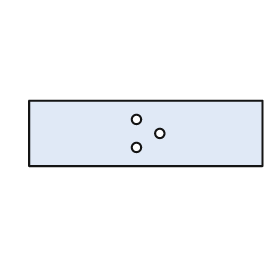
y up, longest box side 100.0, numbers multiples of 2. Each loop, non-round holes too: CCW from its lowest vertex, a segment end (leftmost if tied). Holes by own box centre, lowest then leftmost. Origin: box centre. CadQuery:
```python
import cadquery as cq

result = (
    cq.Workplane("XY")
    .moveTo(-50.0, -14.0)
    .lineTo(50.0, -14.0)
    .lineTo(50.0, 14.0)
    .lineTo(-50.0, 14.0)
    .close()
    .moveTo(-4.0, -6.0)
    .circle(2.0)
    .moveTo(6.0, 0.0)
    .circle(2.0)
    .moveTo(-4.0, 6.0)
    .circle(2.0)
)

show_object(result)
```